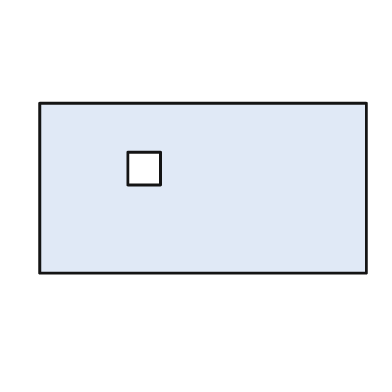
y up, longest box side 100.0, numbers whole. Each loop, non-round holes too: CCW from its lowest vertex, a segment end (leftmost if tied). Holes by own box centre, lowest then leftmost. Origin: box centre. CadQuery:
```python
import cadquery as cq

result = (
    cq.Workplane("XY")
    .moveTo(-50.0, -26.0)
    .lineTo(50.0, -26.0)
    .lineTo(50.0, 26.0)
    .lineTo(-50.0, 26.0)
    .close()
    .moveTo(-23.0, 1.0)
    .lineTo(-13.0, 1.0)
    .lineTo(-13.0, 11.0)
    .lineTo(-23.0, 11.0)
    .close()
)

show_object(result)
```